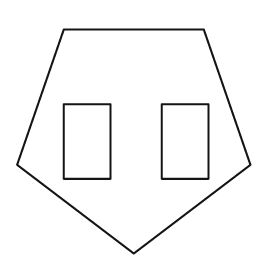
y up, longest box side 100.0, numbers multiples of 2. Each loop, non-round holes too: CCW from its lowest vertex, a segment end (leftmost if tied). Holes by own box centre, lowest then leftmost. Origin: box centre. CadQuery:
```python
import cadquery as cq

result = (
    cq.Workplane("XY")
    .moveTo(0.0, -48.0)
    .lineTo(50.0, -10.0)
    .lineTo(30.0, 48.0)
    .lineTo(-30.0, 48.0)
    .lineTo(-50.0, -10.0)
    .close()
    .moveTo(-30.0, -16.0)
    .lineTo(-10.0, -16.0)
    .lineTo(-10.0, 16.0)
    .lineTo(-30.0, 16.0)
    .close()
    .moveTo(12.0, -16.0)
    .lineTo(32.0, -16.0)
    .lineTo(32.0, 16.0)
    .lineTo(12.0, 16.0)
    .close()
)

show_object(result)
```